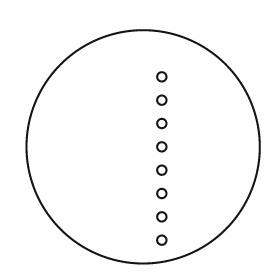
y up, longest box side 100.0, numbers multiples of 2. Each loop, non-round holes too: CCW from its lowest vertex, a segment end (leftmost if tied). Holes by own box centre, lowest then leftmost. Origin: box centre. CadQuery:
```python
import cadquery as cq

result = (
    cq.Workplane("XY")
    .moveTo(0.0, 0.0)
    .circle(50.0)
    .moveTo(8.0, -40.0)
    .circle(2.0)
    .moveTo(8.0, -30.0)
    .circle(2.0)
    .moveTo(8.0, -20.0)
    .circle(2.0)
    .moveTo(8.0, -10.0)
    .circle(2.0)
    .moveTo(8.0, 0.0)
    .circle(2.0)
    .moveTo(8.0, 10.0)
    .circle(2.0)
    .moveTo(8.0, 20.0)
    .circle(2.0)
    .moveTo(8.0, 30.0)
    .circle(2.0)
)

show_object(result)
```